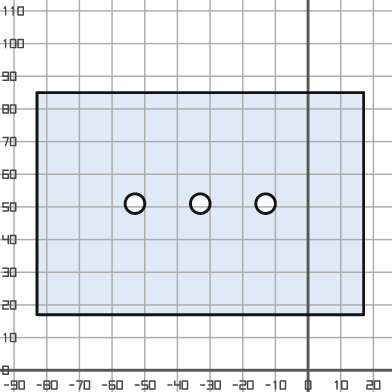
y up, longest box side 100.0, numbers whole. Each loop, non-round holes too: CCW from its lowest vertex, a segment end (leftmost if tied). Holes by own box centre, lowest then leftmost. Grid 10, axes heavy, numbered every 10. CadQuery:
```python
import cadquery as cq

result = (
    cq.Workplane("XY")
    .moveTo(-83.0, 17.0)
    .lineTo(17.0, 17.0)
    .lineTo(17.0, 85.0)
    .lineTo(-83.0, 85.0)
    .close()
    .moveTo(-53.0, 51.0)
    .circle(3.0)
    .moveTo(-33.0, 51.0)
    .circle(3.0)
    .moveTo(-13.0, 51.0)
    .circle(3.0)
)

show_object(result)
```